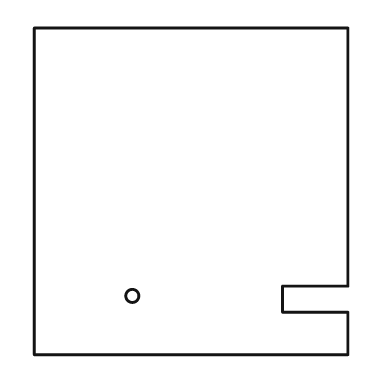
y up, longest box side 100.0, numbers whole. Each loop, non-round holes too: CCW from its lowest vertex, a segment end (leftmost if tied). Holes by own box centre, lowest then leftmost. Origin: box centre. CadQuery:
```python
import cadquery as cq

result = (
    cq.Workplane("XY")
    .moveTo(-48.0, -50.0)
    .lineTo(48.0, -50.0)
    .lineTo(48.0, -37.0)
    .lineTo(28.0, -37.0)
    .lineTo(28.0, -29.0)
    .lineTo(48.0, -29.0)
    .lineTo(48.0, 50.0)
    .lineTo(-48.0, 50.0)
    .close()
    .moveTo(-18.0, -32.0)
    .circle(2.0)
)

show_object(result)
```